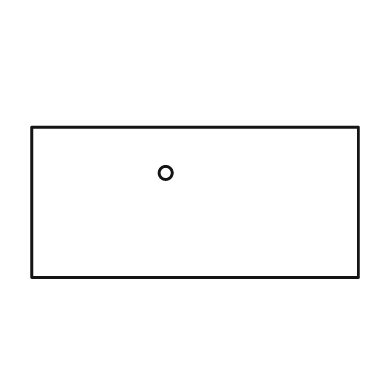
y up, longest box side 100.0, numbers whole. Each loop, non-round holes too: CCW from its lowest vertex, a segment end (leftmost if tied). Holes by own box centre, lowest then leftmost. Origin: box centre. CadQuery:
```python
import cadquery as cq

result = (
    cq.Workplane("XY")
    .moveTo(-50.0, -23.0)
    .lineTo(50.0, -23.0)
    .lineTo(50.0, 23.0)
    .lineTo(-50.0, 23.0)
    .close()
    .moveTo(-9.0, 9.0)
    .circle(2.0)
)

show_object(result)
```